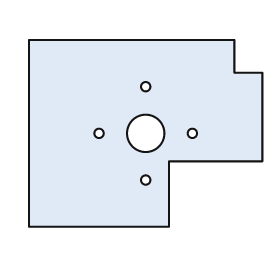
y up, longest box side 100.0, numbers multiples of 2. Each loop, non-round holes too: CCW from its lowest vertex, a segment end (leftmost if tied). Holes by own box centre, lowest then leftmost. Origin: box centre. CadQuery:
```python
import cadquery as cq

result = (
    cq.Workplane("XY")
    .moveTo(-50.0, -40.0)
    .lineTo(10.0, -40.0)
    .lineTo(10.0, -12.0)
    .lineTo(50.0, -12.0)
    .lineTo(50.0, 26.0)
    .lineTo(38.0, 26.0)
    .lineTo(38.0, 40.0)
    .lineTo(-50.0, 40.0)
    .close()
    .moveTo(0.0, -20.0)
    .circle(2.0)
    .moveTo(-20.0, 0.0)
    .circle(2.0)
    .moveTo(0.0, 0.0)
    .circle(8.0)
    .moveTo(20.0, 0.0)
    .circle(2.0)
    .moveTo(0.0, 20.0)
    .circle(2.0)
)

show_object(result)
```